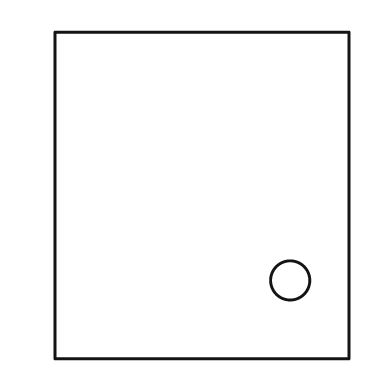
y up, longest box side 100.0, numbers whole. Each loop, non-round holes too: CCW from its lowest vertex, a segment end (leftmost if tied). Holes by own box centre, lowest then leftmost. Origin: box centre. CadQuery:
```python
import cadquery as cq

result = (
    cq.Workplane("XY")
    .moveTo(-45.0, -50.0)
    .lineTo(45.0, -50.0)
    .lineTo(45.0, 50.0)
    .lineTo(-45.0, 50.0)
    .close()
    .moveTo(27.0, -26.0)
    .circle(6.0)
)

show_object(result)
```